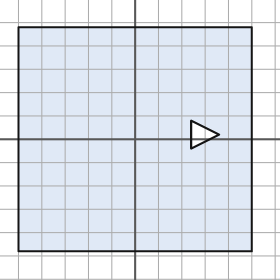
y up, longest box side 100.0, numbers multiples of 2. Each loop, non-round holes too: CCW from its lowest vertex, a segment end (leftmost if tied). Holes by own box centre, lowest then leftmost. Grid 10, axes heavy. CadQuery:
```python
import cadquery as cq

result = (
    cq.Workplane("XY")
    .moveTo(-50.0, -48.0)
    .lineTo(50.0, -48.0)
    .lineTo(50.0, 48.0)
    .lineTo(-50.0, 48.0)
    .close()
    .moveTo(24.0, -4.0)
    .lineTo(36.0, 2.0)
    .lineTo(24.0, 8.0)
    .close()
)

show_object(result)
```